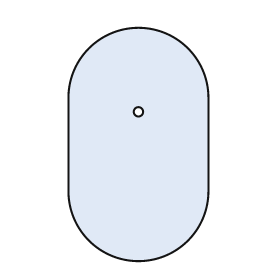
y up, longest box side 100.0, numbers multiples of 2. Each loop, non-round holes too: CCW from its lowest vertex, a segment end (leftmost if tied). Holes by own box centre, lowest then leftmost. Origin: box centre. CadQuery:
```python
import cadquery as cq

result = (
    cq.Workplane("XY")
    .moveTo(-30.0, -20.0)
    .threePointArc((0.0, -50.0), (30.0, -20.0))
    .lineTo(30.0, 20.0)
    .threePointArc((0.0, 50.0), (-30.0, 20.0))
    .close()
    .moveTo(0.0, 14.0)
    .circle(2.0)
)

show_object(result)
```